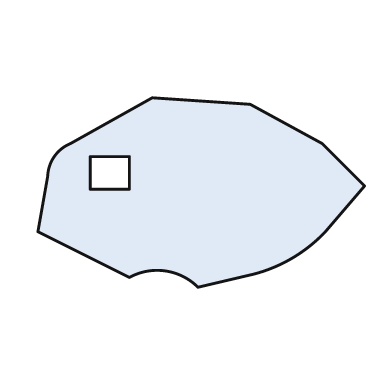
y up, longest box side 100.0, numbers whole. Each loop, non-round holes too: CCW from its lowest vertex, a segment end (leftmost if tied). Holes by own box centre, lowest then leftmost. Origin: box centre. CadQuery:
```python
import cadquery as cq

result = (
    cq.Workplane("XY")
    .moveTo(-1.0, -29.0)
    .lineTo(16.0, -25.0)
    .threePointArc((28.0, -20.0), (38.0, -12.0))
    .lineTo(50.0, 2.0)
    .lineTo(37.0, 15.0)
    .lineTo(15.0, 27.0)
    .lineTo(-15.0, 29.0)
    .lineTo(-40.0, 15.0)
    .threePointArc((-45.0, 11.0), (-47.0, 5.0))
    .lineTo(-50.0, -12.0)
    .lineTo(-22.0, -26.0)
    .threePointArc((-11.0, -24.0), (-1.0, -29.0))
    .close()
    .moveTo(-34.0, 1.0)
    .lineTo(-22.0, 1.0)
    .lineTo(-22.0, 11.0)
    .lineTo(-34.0, 11.0)
    .close()
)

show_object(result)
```